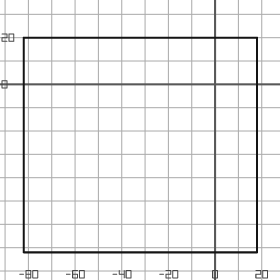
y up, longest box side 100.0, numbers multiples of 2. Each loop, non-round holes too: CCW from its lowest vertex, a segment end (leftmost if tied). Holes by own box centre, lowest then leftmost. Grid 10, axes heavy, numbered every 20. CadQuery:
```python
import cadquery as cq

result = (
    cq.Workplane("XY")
    .moveTo(-82.0, -72.0)
    .lineTo(18.0, -72.0)
    .lineTo(18.0, 20.0)
    .lineTo(-82.0, 20.0)
    .close()
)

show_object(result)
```